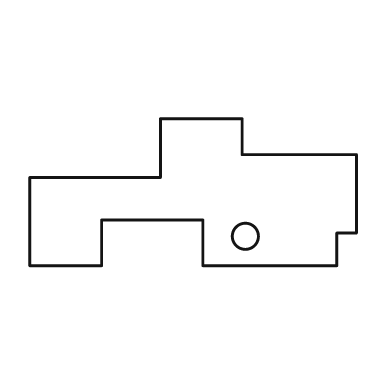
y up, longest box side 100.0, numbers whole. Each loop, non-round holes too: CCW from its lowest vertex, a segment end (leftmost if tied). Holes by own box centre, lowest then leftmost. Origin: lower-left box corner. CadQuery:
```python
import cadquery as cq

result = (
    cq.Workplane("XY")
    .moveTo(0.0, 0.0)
    .lineTo(22.0, 0.0)
    .lineTo(22.0, 14.0)
    .lineTo(53.0, 14.0)
    .lineTo(53.0, 0.0)
    .lineTo(94.0, 0.0)
    .lineTo(94.0, 10.0)
    .lineTo(100.0, 10.0)
    .lineTo(100.0, 34.0)
    .lineTo(65.0, 34.0)
    .lineTo(65.0, 45.0)
    .lineTo(40.0, 45.0)
    .lineTo(40.0, 27.0)
    .lineTo(0.0, 27.0)
    .close()
    .moveTo(66.0, 9.0)
    .circle(4.0)
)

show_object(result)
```